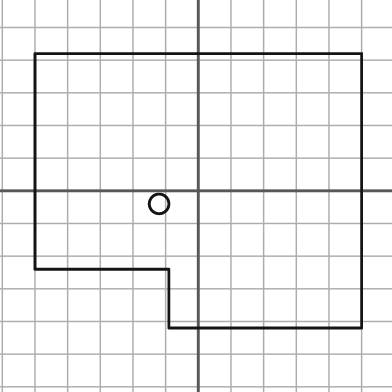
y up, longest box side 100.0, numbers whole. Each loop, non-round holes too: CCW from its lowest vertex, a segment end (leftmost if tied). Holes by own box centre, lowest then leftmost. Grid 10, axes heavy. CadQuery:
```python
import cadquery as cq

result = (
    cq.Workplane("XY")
    .moveTo(-9.0, -42.0)
    .lineTo(50.0, -42.0)
    .lineTo(50.0, 42.0)
    .lineTo(-50.0, 42.0)
    .lineTo(-50.0, -24.0)
    .lineTo(-9.0, -24.0)
    .close()
    .moveTo(-12.0, -4.0)
    .circle(3.0)
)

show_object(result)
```